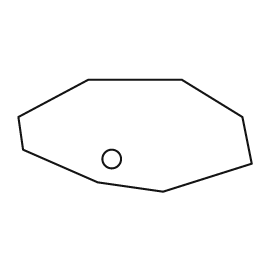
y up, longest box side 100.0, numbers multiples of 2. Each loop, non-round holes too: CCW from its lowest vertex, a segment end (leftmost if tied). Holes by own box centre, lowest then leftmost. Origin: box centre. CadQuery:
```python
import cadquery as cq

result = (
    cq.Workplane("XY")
    .moveTo(12.0, -24.0)
    .lineTo(50.0, -12.0)
    .lineTo(46.0, 8.0)
    .lineTo(20.0, 24.0)
    .lineTo(-20.0, 24.0)
    .lineTo(-50.0, 8.0)
    .lineTo(-48.0, -6.0)
    .lineTo(-16.0, -20.0)
    .close()
    .moveTo(-10.0, -10.0)
    .circle(4.0)
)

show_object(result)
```